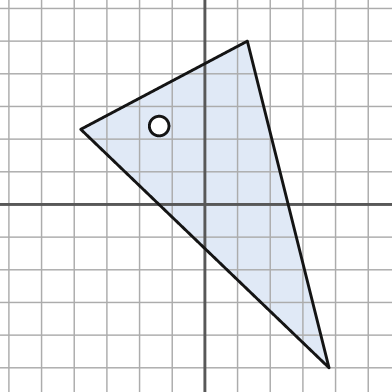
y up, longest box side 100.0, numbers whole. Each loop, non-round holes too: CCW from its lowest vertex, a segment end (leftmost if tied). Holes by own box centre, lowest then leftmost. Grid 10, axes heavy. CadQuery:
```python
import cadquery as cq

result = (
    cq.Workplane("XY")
    .moveTo(38.0, -50.0)
    .lineTo(13.0, 50.0)
    .lineTo(-38.0, 23.0)
    .close()
    .moveTo(-14.0, 24.0)
    .circle(3.0)
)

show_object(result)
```